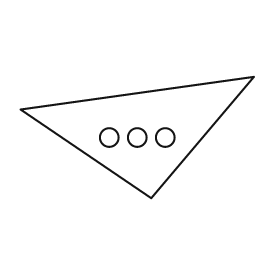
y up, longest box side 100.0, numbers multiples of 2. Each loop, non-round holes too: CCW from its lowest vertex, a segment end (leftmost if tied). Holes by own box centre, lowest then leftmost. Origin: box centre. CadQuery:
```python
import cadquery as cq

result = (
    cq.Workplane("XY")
    .moveTo(6.0, -26.0)
    .lineTo(50.0, 26.0)
    .lineTo(-50.0, 12.0)
    .close()
    .moveTo(-12.0, 0.0)
    .circle(4.0)
    .moveTo(0.0, 0.0)
    .circle(4.0)
    .moveTo(12.0, 0.0)
    .circle(4.0)
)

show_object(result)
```